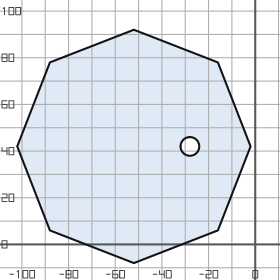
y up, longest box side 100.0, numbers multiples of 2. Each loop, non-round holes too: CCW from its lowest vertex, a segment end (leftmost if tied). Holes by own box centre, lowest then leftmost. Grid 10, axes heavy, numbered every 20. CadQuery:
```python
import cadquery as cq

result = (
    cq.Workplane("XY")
    .moveTo(-52.0, -8.0)
    .lineTo(-16.0, 6.0)
    .lineTo(-2.0, 42.0)
    .lineTo(-16.0, 78.0)
    .lineTo(-52.0, 92.0)
    .lineTo(-88.0, 78.0)
    .lineTo(-102.0, 42.0)
    .lineTo(-88.0, 6.0)
    .close()
    .moveTo(-28.0, 42.0)
    .circle(4.0)
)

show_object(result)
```